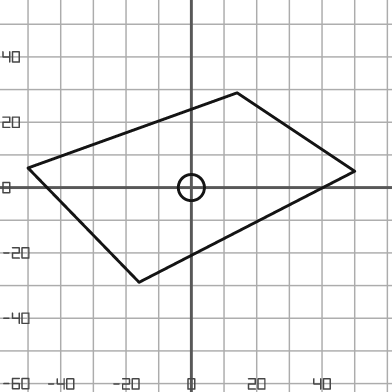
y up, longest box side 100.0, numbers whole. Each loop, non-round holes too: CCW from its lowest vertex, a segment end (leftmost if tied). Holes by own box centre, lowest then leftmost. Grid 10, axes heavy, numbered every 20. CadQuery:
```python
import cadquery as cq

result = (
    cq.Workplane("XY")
    .moveTo(-16.0, -29.0)
    .lineTo(50.0, 5.0)
    .lineTo(14.0, 29.0)
    .lineTo(-50.0, 6.0)
    .close()
    .moveTo(0.0, 0.0)
    .circle(4.0)
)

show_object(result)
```